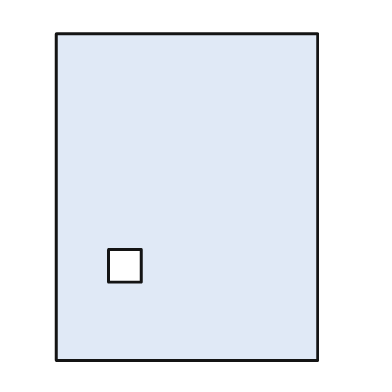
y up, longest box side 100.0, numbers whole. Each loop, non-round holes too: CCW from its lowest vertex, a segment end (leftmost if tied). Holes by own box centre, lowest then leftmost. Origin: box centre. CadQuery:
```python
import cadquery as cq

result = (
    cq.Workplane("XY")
    .moveTo(-40.0, -50.0)
    .lineTo(40.0, -50.0)
    .lineTo(40.0, 50.0)
    .lineTo(-40.0, 50.0)
    .close()
    .moveTo(-24.0, -26.0)
    .lineTo(-14.0, -26.0)
    .lineTo(-14.0, -16.0)
    .lineTo(-24.0, -16.0)
    .close()
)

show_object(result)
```